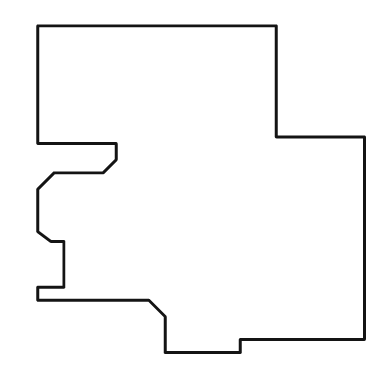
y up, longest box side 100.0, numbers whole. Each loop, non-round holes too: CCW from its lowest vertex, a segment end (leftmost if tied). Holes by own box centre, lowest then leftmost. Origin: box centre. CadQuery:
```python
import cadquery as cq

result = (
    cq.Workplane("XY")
    .moveTo(-11.0, -50.0)
    .lineTo(12.0, -50.0)
    .lineTo(12.0, -46.0)
    .lineTo(50.0, -46.0)
    .lineTo(50.0, 16.0)
    .lineTo(23.0, 16.0)
    .lineTo(23.0, 50.0)
    .lineTo(-50.0, 50.0)
    .lineTo(-50.0, 14.0)
    .lineTo(-26.0, 14.0)
    .lineTo(-26.0, 9.0)
    .lineTo(-30.0, 5.0)
    .lineTo(-45.0, 5.0)
    .lineTo(-50.0, 0.0)
    .lineTo(-50.0, -13.0)
    .lineTo(-46.0, -16.0)
    .lineTo(-42.0, -16.0)
    .lineTo(-42.0, -30.0)
    .lineTo(-50.0, -30.0)
    .lineTo(-50.0, -34.0)
    .lineTo(-16.0, -34.0)
    .lineTo(-11.0, -39.0)
    .close()
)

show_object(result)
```